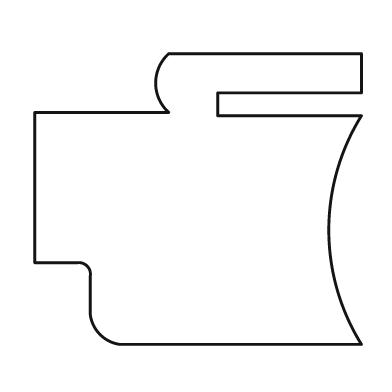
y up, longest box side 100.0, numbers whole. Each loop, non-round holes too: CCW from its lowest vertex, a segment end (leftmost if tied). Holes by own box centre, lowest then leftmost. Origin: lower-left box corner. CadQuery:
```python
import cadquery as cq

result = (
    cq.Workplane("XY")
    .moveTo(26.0, 0.0)
    .lineTo(100.0, 0.0)
    .threePointArc((90.0, 35.0), (100.0, 70.0))
    .lineTo(56.0, 70.0)
    .lineTo(56.0, 77.0)
    .lineTo(100.0, 77.0)
    .lineTo(100.0, 89.0)
    .lineTo(41.0, 89.0)
    .threePointArc((37.0, 80.0), (41.0, 71.0))
    .lineTo(0.0, 71.0)
    .lineTo(0.0, 25.0)
    .lineTo(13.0, 25.0)
    .threePointArc((16.0, 24.0), (17.0, 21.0))
    .lineTo(17.0, 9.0)
    .threePointArc((20.0, 3.0), (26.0, 0.0))
    .close()
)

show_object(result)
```